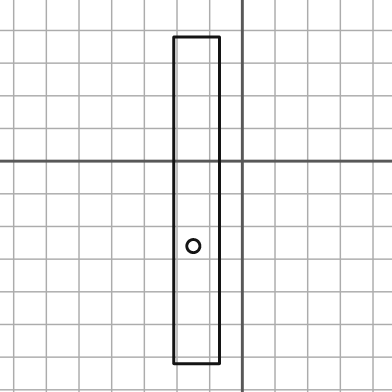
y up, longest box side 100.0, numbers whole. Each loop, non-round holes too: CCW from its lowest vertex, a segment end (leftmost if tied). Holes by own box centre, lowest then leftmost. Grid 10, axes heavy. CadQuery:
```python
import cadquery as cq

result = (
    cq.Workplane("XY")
    .moveTo(-21.0, -62.0)
    .lineTo(-7.0, -62.0)
    .lineTo(-7.0, 38.0)
    .lineTo(-21.0, 38.0)
    .close()
    .moveTo(-15.0, -26.0)
    .circle(2.0)
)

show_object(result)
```